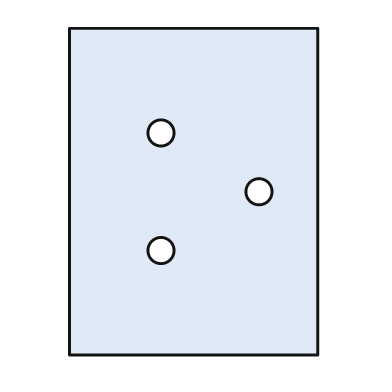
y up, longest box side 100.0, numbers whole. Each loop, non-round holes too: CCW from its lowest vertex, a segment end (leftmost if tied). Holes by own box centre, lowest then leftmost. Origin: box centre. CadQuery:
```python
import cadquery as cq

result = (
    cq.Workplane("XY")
    .moveTo(-38.0, -50.0)
    .lineTo(38.0, -50.0)
    .lineTo(38.0, 50.0)
    .lineTo(-38.0, 50.0)
    .close()
    .moveTo(-10.0, -18.0)
    .circle(4.0)
    .moveTo(20.0, 0.0)
    .circle(4.0)
    .moveTo(-10.0, 18.0)
    .circle(4.0)
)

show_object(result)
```